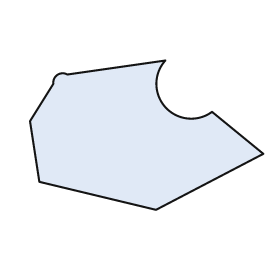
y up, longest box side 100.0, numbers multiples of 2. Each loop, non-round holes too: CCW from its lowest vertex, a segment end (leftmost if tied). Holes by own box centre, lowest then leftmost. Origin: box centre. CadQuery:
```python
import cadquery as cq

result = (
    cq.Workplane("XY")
    .moveTo(4.0, -32.0)
    .lineTo(50.0, -8.0)
    .lineTo(28.0, 10.0)
    .threePointArc((8.0, 12.0), (8.0, 32.0))
    .lineTo(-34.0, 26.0)
    .threePointArc((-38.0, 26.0), (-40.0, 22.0))
    .lineTo(-50.0, 6.0)
    .lineTo(-46.0, -20.0)
    .close()
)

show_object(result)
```